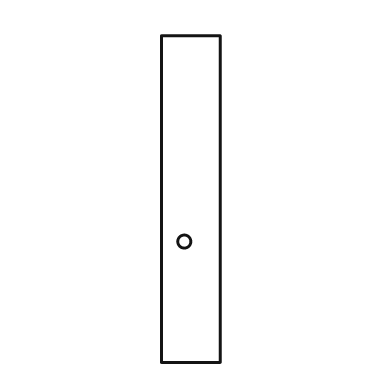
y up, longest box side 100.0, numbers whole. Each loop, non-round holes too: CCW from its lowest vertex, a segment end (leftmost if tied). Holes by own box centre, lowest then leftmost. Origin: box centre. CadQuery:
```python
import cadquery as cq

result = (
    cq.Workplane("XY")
    .moveTo(-9.0, -50.0)
    .lineTo(9.0, -50.0)
    .lineTo(9.0, 50.0)
    .lineTo(-9.0, 50.0)
    .close()
    .moveTo(-2.0, -13.0)
    .circle(2.0)
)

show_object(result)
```